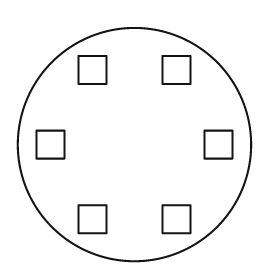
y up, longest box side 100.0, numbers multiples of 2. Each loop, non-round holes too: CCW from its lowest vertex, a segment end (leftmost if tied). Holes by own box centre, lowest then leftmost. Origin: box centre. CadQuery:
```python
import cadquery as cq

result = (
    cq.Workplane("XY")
    .moveTo(0.0, 0.0)
    .circle(50.0)
    .moveTo(-24.0, -38.0)
    .lineTo(-12.0, -38.0)
    .lineTo(-12.0, -26.0)
    .lineTo(-24.0, -26.0)
    .close()
    .moveTo(12.0, -38.0)
    .lineTo(24.0, -38.0)
    .lineTo(24.0, -26.0)
    .lineTo(12.0, -26.0)
    .close()
    .moveTo(-42.0, -6.0)
    .lineTo(-30.0, -6.0)
    .lineTo(-30.0, 6.0)
    .lineTo(-42.0, 6.0)
    .close()
    .moveTo(30.0, -6.0)
    .lineTo(42.0, -6.0)
    .lineTo(42.0, 6.0)
    .lineTo(30.0, 6.0)
    .close()
    .moveTo(-24.0, 26.0)
    .lineTo(-12.0, 26.0)
    .lineTo(-12.0, 38.0)
    .lineTo(-24.0, 38.0)
    .close()
    .moveTo(12.0, 26.0)
    .lineTo(24.0, 26.0)
    .lineTo(24.0, 38.0)
    .lineTo(12.0, 38.0)
    .close()
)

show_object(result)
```